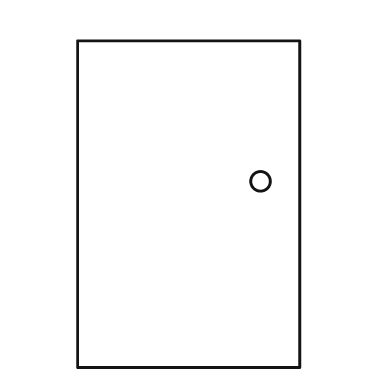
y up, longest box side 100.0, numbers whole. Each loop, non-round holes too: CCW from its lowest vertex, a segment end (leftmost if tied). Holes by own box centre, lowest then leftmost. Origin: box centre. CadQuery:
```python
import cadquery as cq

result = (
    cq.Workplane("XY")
    .moveTo(-34.0, -50.0)
    .lineTo(34.0, -50.0)
    .lineTo(34.0, 50.0)
    .lineTo(-34.0, 50.0)
    .close()
    .moveTo(22.0, 7.0)
    .circle(3.0)
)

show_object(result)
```